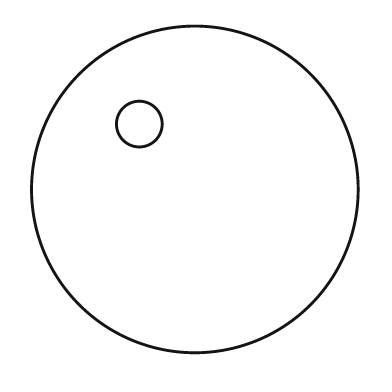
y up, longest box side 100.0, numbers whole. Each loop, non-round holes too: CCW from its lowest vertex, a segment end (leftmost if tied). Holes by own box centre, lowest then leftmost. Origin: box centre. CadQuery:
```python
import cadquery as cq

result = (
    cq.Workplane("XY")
    .moveTo(0.0, 0.0)
    .circle(50.0)
    .moveTo(-17.0, 20.0)
    .circle(7.0)
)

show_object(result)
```